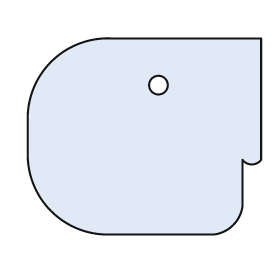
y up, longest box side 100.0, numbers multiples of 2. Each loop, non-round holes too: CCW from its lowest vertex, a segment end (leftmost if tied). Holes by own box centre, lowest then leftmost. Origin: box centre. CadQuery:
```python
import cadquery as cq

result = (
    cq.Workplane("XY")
    .moveTo(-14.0, -42.0)
    .lineTo(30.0, -42.0)
    .threePointArc((38.0, -38.0), (42.0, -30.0))
    .lineTo(42.0, -10.0)
    .threePointArc((46.0, -12.0), (50.0, -10.0))
    .lineTo(50.0, 42.0)
    .lineTo(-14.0, 42.0)
    .threePointArc((-40.0, 32.0), (-50.0, 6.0))
    .lineTo(-50.0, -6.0)
    .threePointArc((-40.0, -32.0), (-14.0, -42.0))
    .close()
    .moveTo(6.0, 22.0)
    .circle(4.0)
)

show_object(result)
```